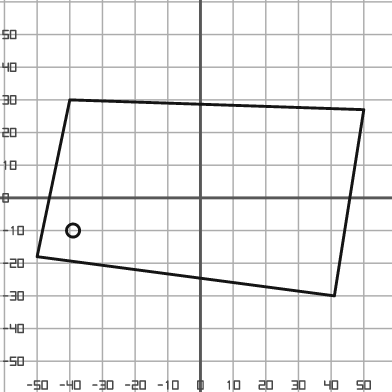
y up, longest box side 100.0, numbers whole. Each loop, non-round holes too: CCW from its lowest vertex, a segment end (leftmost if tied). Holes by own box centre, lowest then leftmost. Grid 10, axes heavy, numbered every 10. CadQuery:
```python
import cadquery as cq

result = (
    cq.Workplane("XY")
    .moveTo(41.0, -30.0)
    .lineTo(50.0, 27.0)
    .lineTo(-40.0, 30.0)
    .lineTo(-50.0, -18.0)
    .close()
    .moveTo(-39.0, -10.0)
    .circle(2.0)
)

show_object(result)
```